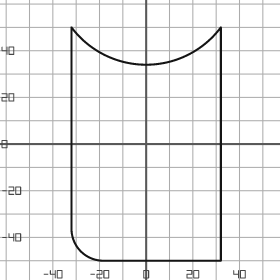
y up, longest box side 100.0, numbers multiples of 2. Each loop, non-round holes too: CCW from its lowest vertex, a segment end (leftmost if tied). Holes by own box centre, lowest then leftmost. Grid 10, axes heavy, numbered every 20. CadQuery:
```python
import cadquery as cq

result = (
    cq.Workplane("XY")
    .moveTo(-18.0, -50.0)
    .lineTo(32.0, -50.0)
    .lineTo(32.0, 50.0)
    .threePointArc((0.0, 34.0), (-32.0, 50.0))
    .lineTo(-32.0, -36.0)
    .threePointArc((-28.0, -46.0), (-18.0, -50.0))
    .close()
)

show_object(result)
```